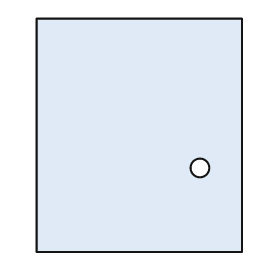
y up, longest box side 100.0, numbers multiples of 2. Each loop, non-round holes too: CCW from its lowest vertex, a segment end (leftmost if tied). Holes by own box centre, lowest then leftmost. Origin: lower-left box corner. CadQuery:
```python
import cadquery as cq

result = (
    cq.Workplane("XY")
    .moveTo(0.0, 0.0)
    .lineTo(88.0, 0.0)
    .lineTo(88.0, 100.0)
    .lineTo(0.0, 100.0)
    .close()
    .moveTo(70.0, 36.0)
    .circle(4.0)
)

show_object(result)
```